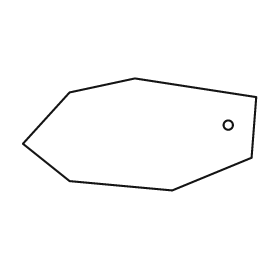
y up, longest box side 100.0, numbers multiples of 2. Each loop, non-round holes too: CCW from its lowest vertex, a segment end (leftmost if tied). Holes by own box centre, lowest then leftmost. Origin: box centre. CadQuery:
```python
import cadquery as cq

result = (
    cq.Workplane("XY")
    .moveTo(14.0, -24.0)
    .lineTo(48.0, -10.0)
    .lineTo(50.0, 16.0)
    .lineTo(-2.0, 24.0)
    .lineTo(-30.0, 18.0)
    .lineTo(-50.0, -4.0)
    .lineTo(-30.0, -20.0)
    .close()
    .moveTo(38.0, 4.0)
    .circle(2.0)
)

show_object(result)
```